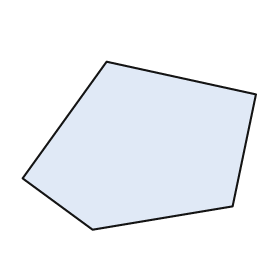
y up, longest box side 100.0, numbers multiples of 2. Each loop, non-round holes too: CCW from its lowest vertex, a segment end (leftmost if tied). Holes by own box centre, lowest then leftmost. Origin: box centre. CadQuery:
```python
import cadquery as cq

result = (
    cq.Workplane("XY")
    .moveTo(-20.0, -36.0)
    .lineTo(40.0, -26.0)
    .lineTo(50.0, 22.0)
    .lineTo(-14.0, 36.0)
    .lineTo(-50.0, -14.0)
    .close()
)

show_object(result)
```